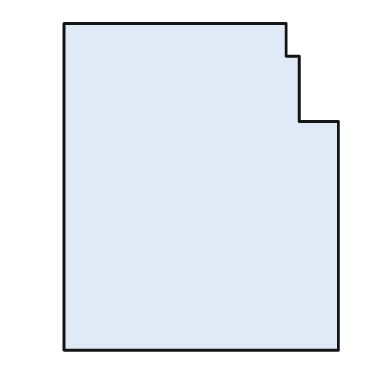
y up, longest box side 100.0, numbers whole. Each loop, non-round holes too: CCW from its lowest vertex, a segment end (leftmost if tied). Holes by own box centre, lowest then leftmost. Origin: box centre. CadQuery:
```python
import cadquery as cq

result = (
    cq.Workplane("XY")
    .moveTo(-42.0, -50.0)
    .lineTo(42.0, -50.0)
    .lineTo(42.0, 20.0)
    .lineTo(30.0, 20.0)
    .lineTo(30.0, 40.0)
    .lineTo(26.0, 40.0)
    .lineTo(26.0, 50.0)
    .lineTo(-42.0, 50.0)
    .close()
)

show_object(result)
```